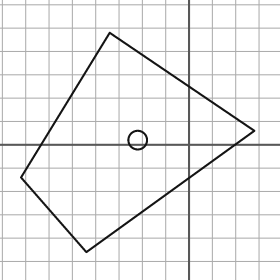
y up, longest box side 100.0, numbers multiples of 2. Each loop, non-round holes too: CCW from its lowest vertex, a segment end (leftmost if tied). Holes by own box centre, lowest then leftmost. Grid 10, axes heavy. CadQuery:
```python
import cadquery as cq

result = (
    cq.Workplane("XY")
    .moveTo(-44.0, -46.0)
    .lineTo(28.0, 6.0)
    .lineTo(-34.0, 48.0)
    .lineTo(-72.0, -14.0)
    .close()
    .moveTo(-22.0, 2.0)
    .circle(4.0)
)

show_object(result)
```